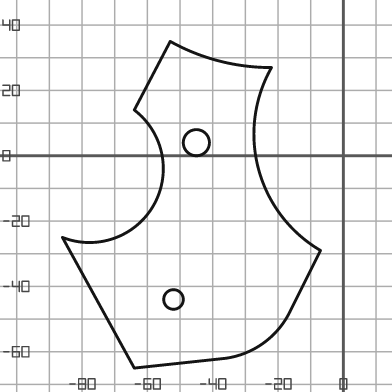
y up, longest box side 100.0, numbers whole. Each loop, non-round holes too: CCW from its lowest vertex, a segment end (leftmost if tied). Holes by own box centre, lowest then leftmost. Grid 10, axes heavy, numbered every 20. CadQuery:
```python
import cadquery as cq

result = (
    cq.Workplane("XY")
    .moveTo(-64.0, -65.0)
    .lineTo(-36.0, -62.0)
    .threePointArc((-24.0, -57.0), (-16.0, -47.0))
    .lineTo(-7.0, -29.0)
    .threePointArc((-26.0, -4.0), (-22.0, 27.0))
    .threePointArc((-38.0, 29.0), (-53.0, 35.0))
    .lineTo(-64.0, 14.0)
    .threePointArc((-58.0, -15.0), (-86.0, -25.0))
    .close()
    .moveTo(-52.0, -44.0)
    .circle(3.0)
    .moveTo(-45.0, 4.0)
    .circle(4.0)
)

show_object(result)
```